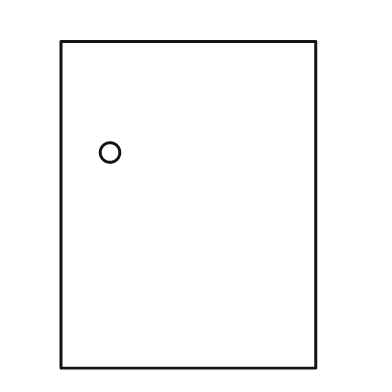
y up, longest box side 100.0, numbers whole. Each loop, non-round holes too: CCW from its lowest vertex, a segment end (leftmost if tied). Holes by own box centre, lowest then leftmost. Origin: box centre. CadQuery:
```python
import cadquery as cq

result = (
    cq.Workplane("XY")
    .moveTo(-39.0, -50.0)
    .lineTo(39.0, -50.0)
    .lineTo(39.0, 50.0)
    .lineTo(-39.0, 50.0)
    .close()
    .moveTo(-24.0, 16.0)
    .circle(3.0)
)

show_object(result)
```